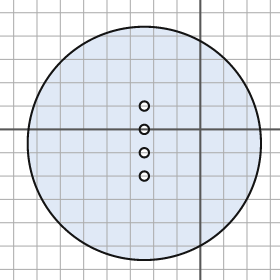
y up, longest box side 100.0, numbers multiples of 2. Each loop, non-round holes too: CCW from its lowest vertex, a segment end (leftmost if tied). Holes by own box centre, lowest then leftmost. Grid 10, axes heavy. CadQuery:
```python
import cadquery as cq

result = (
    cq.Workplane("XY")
    .moveTo(-24.0, -6.0)
    .circle(50.0)
    .moveTo(-24.0, -20.0)
    .circle(2.0)
    .moveTo(-24.0, -10.0)
    .circle(2.0)
    .moveTo(-24.0, 0.0)
    .circle(2.0)
    .moveTo(-24.0, 10.0)
    .circle(2.0)
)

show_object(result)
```